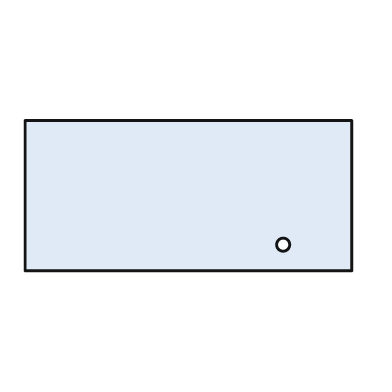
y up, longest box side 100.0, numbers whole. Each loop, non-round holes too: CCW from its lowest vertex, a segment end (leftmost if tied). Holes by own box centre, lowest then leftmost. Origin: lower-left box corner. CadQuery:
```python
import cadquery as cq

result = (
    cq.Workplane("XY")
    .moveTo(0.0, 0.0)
    .lineTo(100.0, 0.0)
    .lineTo(100.0, 46.0)
    .lineTo(0.0, 46.0)
    .close()
    .moveTo(79.0, 8.0)
    .circle(2.0)
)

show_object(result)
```